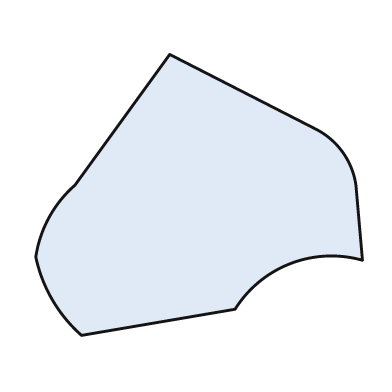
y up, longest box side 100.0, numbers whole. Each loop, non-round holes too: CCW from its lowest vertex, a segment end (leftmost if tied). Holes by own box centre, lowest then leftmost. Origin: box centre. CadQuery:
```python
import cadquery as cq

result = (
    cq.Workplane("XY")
    .moveTo(-36.0, -43.0)
    .lineTo(11.0, -35.0)
    .threePointArc((28.0, -21.0), (50.0, -20.0))
    .lineTo(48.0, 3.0)
    .threePointArc((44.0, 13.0), (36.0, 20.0))
    .lineTo(-9.0, 43.0)
    .lineTo(-38.0, 3.0)
    .threePointArc((-46.0, -7.0), (-50.0, -19.0))
    .threePointArc((-45.0, -32.0), (-36.0, -43.0))
    .close()
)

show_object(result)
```